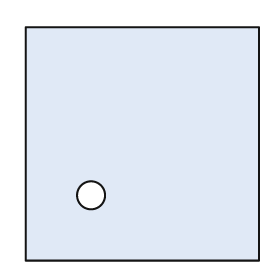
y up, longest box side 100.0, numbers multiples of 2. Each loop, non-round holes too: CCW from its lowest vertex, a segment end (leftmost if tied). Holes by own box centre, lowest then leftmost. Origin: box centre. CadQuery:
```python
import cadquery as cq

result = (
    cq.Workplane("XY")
    .moveTo(-50.0, -50.0)
    .lineTo(50.0, -50.0)
    .lineTo(50.0, 50.0)
    .lineTo(-50.0, 50.0)
    .close()
    .moveTo(-22.0, -22.0)
    .circle(6.0)
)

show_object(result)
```